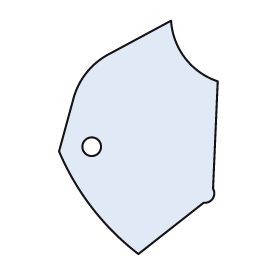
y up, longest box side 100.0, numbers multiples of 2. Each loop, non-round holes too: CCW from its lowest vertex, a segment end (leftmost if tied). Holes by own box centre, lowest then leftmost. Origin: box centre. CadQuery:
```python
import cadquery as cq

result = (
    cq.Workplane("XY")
    .moveTo(0.0, -50.0)
    .lineTo(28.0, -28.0)
    .threePointArc((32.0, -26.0), (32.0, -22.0))
    .lineTo(34.0, 24.0)
    .threePointArc((20.0, 34.0), (14.0, 50.0))
    .lineTo(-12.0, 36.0)
    .threePointArc((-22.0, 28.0), (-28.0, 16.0))
    .lineTo(-34.0, -6.0)
    .threePointArc((-20.0, -30.0), (0.0, -50.0))
    .close()
    .moveTo(-20.0, -4.0)
    .circle(4.0)
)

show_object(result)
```